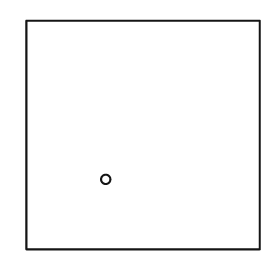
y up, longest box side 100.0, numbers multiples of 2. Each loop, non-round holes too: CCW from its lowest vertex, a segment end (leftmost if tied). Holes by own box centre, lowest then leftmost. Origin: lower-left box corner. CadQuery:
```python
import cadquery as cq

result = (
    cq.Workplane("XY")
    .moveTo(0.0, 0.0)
    .lineTo(100.0, 0.0)
    .lineTo(100.0, 98.0)
    .lineTo(0.0, 98.0)
    .close()
    .moveTo(34.0, 30.0)
    .circle(2.0)
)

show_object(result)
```